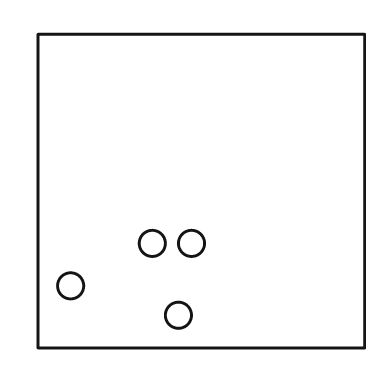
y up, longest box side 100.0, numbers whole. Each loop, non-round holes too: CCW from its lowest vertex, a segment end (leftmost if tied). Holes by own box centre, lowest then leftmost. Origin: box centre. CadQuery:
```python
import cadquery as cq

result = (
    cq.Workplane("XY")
    .moveTo(-50.0, -48.0)
    .lineTo(50.0, -48.0)
    .lineTo(50.0, 48.0)
    .lineTo(-50.0, 48.0)
    .close()
    .moveTo(-7.0, -38.0)
    .circle(4.0)
    .moveTo(-40.0, -29.0)
    .circle(4.0)
    .moveTo(-15.0, -16.0)
    .circle(4.0)
    .moveTo(-3.0, -16.0)
    .circle(4.0)
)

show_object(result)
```